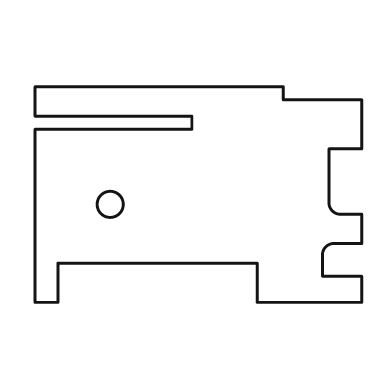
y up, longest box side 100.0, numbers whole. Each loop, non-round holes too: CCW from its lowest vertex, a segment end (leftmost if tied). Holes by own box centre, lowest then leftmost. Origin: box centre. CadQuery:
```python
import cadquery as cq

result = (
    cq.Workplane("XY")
    .moveTo(-50.0, -33.0)
    .lineTo(-43.0, -33.0)
    .lineTo(-43.0, -21.0)
    .lineTo(18.0, -21.0)
    .lineTo(18.0, -33.0)
    .lineTo(50.0, -33.0)
    .lineTo(50.0, -25.0)
    .lineTo(38.0, -25.0)
    .lineTo(38.0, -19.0)
    .threePointArc((39.0, -16.0), (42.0, -15.0))
    .lineTo(50.0, -15.0)
    .lineTo(50.0, -6.0)
    .lineTo(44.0, -6.0)
    .threePointArc((41.0, -5.0), (40.0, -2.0))
    .lineTo(40.0, 14.0)
    .lineTo(50.0, 14.0)
    .lineTo(50.0, 29.0)
    .lineTo(26.0, 29.0)
    .lineTo(26.0, 33.0)
    .lineTo(-50.0, 33.0)
    .lineTo(-50.0, 24.0)
    .lineTo(-2.0, 24.0)
    .lineTo(-2.0, 20.0)
    .lineTo(-50.0, 20.0)
    .close()
    .moveTo(-27.0, -3.0)
    .circle(4.0)
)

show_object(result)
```